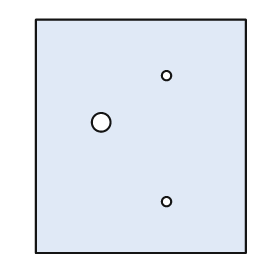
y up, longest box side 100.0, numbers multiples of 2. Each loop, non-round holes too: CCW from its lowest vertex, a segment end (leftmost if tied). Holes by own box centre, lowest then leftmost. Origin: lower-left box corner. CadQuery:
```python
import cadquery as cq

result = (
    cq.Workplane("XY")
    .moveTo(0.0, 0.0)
    .lineTo(90.0, 0.0)
    .lineTo(90.0, 100.0)
    .lineTo(0.0, 100.0)
    .close()
    .moveTo(56.0, 22.0)
    .circle(2.0)
    .moveTo(28.0, 56.0)
    .circle(4.0)
    .moveTo(56.0, 76.0)
    .circle(2.0)
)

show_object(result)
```